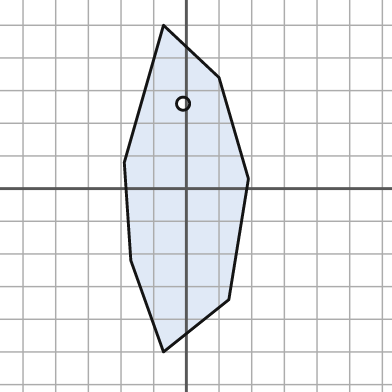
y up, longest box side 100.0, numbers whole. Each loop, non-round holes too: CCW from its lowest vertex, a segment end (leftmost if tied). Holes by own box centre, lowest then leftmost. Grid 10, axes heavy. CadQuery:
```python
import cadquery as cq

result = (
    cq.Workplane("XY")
    .moveTo(-7.0, -50.0)
    .lineTo(13.0, -34.0)
    .lineTo(19.0, 3.0)
    .lineTo(10.0, 34.0)
    .lineTo(-7.0, 50.0)
    .lineTo(-19.0, 8.0)
    .lineTo(-17.0, -22.0)
    .close()
    .moveTo(-1.0, 26.0)
    .circle(2.0)
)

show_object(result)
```